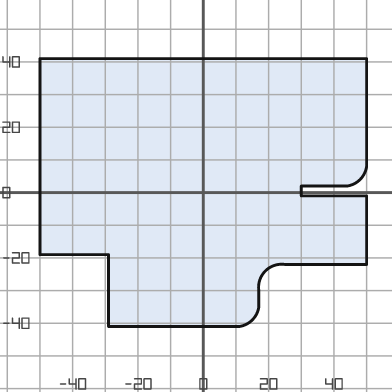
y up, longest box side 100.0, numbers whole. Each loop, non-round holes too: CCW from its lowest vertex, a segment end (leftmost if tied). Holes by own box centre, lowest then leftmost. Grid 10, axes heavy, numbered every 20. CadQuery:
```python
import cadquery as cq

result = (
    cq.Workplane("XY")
    .moveTo(-29.0, -41.0)
    .lineTo(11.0, -41.0)
    .threePointArc((15.0, -39.0), (17.0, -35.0))
    .lineTo(17.0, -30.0)
    .threePointArc((19.0, -24.0), (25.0, -22.0))
    .lineTo(50.0, -22.0)
    .lineTo(50.0, -1.0)
    .lineTo(30.0, -1.0)
    .lineTo(30.0, 2.0)
    .lineTo(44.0, 2.0)
    .threePointArc((48.0, 4.0), (50.0, 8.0))
    .lineTo(50.0, 41.0)
    .lineTo(-50.0, 41.0)
    .lineTo(-50.0, -19.0)
    .lineTo(-29.0, -19.0)
    .close()
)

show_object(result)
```